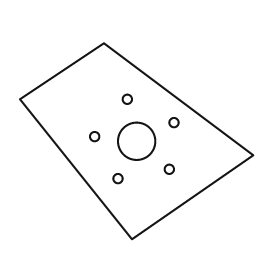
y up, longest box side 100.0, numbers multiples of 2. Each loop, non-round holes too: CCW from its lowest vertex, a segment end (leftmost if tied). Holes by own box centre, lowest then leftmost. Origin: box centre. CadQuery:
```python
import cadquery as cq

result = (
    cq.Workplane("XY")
    .moveTo(-2.0, -42.0)
    .lineTo(50.0, -6.0)
    .lineTo(-14.0, 42.0)
    .lineTo(-50.0, 18.0)
    .close()
    .moveTo(-8.0, -16.0)
    .circle(2.0)
    .moveTo(14.0, -12.0)
    .circle(2.0)
    .moveTo(0.0, 0.0)
    .circle(8.0)
    .moveTo(-18.0, 2.0)
    .circle(2.0)
    .moveTo(16.0, 8.0)
    .circle(2.0)
    .moveTo(-4.0, 18.0)
    .circle(2.0)
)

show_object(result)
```